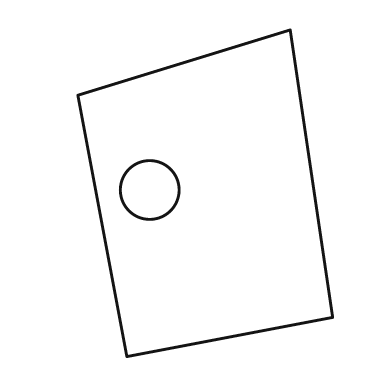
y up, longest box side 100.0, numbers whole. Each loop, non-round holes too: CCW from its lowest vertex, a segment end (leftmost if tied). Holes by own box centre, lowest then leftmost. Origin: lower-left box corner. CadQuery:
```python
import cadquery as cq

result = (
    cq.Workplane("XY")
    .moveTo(15.0, 0.0)
    .lineTo(78.0, 12.0)
    .lineTo(65.0, 100.0)
    .lineTo(0.0, 80.0)
    .close()
    .moveTo(22.0, 51.0)
    .circle(9.0)
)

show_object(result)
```